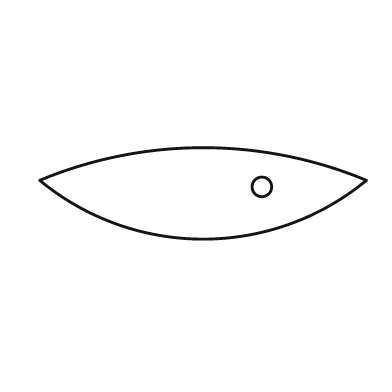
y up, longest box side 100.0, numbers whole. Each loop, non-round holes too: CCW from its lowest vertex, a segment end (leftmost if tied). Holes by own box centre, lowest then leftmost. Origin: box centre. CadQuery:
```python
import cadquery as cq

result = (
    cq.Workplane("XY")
    .moveTo(-50.0, 4.0)
    .threePointArc((0.0, -14.0), (50.0, 4.0))
    .threePointArc((0.0, 14.0), (-50.0, 4.0))
    .close()
    .moveTo(18.0, 2.0)
    .circle(3.0)
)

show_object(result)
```